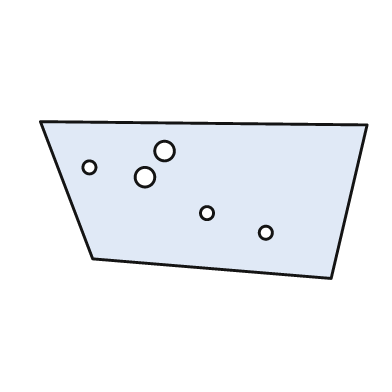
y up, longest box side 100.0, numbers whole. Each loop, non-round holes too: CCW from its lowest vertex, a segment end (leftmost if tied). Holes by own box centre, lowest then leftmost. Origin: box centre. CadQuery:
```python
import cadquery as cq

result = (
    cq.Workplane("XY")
    .moveTo(39.0, -24.0)
    .lineTo(50.0, 23.0)
    .lineTo(-50.0, 24.0)
    .lineTo(-34.0, -18.0)
    .close()
    .moveTo(19.0, -10.0)
    .circle(2.0)
    .moveTo(1.0, -4.0)
    .circle(2.0)
    .moveTo(-18.0, 7.0)
    .circle(3.0)
    .moveTo(-35.0, 10.0)
    .circle(2.0)
    .moveTo(-12.0, 15.0)
    .circle(3.0)
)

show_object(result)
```